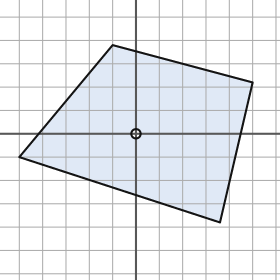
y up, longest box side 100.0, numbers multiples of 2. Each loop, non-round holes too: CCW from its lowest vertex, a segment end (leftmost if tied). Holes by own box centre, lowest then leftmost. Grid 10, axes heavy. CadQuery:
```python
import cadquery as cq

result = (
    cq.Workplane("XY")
    .moveTo(36.0, -38.0)
    .lineTo(50.0, 22.0)
    .lineTo(-10.0, 38.0)
    .lineTo(-50.0, -10.0)
    .close()
    .moveTo(0.0, 0.0)
    .circle(2.0)
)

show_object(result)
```